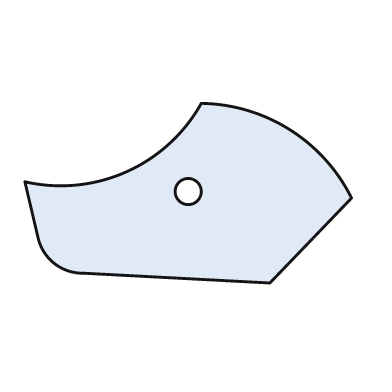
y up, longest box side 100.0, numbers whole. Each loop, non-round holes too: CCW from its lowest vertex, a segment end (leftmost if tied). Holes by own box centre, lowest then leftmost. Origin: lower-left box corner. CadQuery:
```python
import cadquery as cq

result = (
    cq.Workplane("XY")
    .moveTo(75.0, 0.0)
    .lineTo(100.0, 26.0)
    .threePointArc((81.0, 47.0), (54.0, 55.0))
    .threePointArc((31.0, 34.0), (0.0, 31.0))
    .lineTo(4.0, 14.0)
    .threePointArc((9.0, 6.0), (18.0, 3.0))
    .close()
    .moveTo(50.0, 28.0)
    .circle(4.0)
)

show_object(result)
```